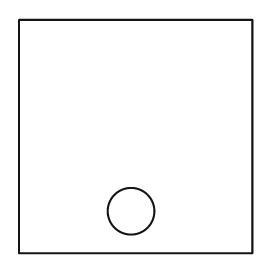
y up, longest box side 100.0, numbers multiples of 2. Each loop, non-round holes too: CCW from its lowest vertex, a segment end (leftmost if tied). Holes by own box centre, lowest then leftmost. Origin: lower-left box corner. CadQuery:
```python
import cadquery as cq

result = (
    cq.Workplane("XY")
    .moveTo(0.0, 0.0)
    .lineTo(100.0, 0.0)
    .lineTo(100.0, 100.0)
    .lineTo(0.0, 100.0)
    .close()
    .moveTo(48.0, 18.0)
    .circle(10.0)
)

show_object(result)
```